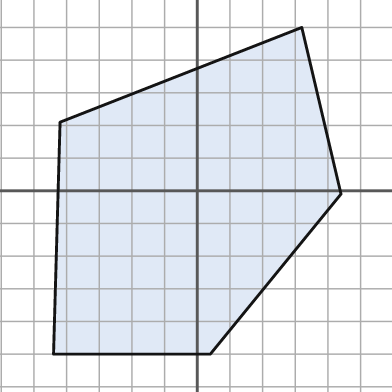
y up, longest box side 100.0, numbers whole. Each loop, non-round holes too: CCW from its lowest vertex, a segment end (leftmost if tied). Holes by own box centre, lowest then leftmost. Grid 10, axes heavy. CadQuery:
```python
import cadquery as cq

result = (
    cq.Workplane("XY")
    .moveTo(-44.0, -50.0)
    .lineTo(4.0, -50.0)
    .lineTo(44.0, -1.0)
    .lineTo(32.0, 50.0)
    .lineTo(-42.0, 21.0)
    .close()
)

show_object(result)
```